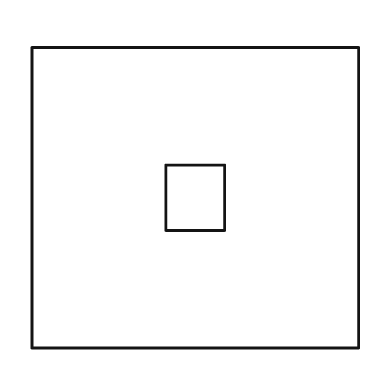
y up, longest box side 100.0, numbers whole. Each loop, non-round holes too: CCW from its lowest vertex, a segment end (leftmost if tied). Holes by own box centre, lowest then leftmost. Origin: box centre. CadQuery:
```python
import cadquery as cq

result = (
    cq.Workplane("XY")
    .moveTo(-50.0, -46.0)
    .lineTo(50.0, -46.0)
    .lineTo(50.0, 46.0)
    .lineTo(-50.0, 46.0)
    .close()
    .moveTo(-9.0, -10.0)
    .lineTo(9.0, -10.0)
    .lineTo(9.0, 10.0)
    .lineTo(-9.0, 10.0)
    .close()
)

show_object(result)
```